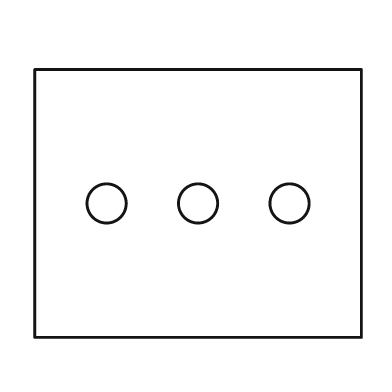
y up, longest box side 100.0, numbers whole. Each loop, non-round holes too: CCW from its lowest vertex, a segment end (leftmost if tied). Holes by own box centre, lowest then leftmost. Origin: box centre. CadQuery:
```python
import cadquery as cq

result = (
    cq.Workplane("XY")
    .moveTo(-50.0, -41.0)
    .lineTo(50.0, -41.0)
    .lineTo(50.0, 41.0)
    .lineTo(-50.0, 41.0)
    .close()
    .moveTo(-28.0, 0.0)
    .circle(6.0)
    .moveTo(0.0, 0.0)
    .circle(6.0)
    .moveTo(28.0, 0.0)
    .circle(6.0)
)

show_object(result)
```